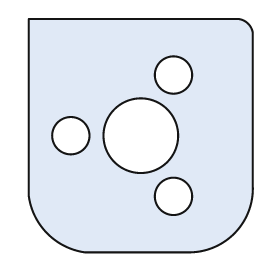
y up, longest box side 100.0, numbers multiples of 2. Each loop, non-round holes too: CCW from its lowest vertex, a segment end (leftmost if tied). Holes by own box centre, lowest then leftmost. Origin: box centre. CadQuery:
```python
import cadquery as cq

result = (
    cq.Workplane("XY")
    .moveTo(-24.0, -50.0)
    .lineTo(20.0, -50.0)
    .threePointArc((40.0, -42.0), (48.0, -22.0))
    .lineTo(48.0, 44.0)
    .threePointArc((46.0, 48.0), (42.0, 50.0))
    .lineTo(-48.0, 50.0)
    .lineTo(-48.0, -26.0)
    .threePointArc((-40.0, -42.0), (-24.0, -50.0))
    .close()
    .moveTo(14.0, -26.0)
    .circle(8.0)
    .moveTo(-30.0, 0.0)
    .circle(8.0)
    .moveTo(0.0, 0.0)
    .circle(16.0)
    .moveTo(14.0, 26.0)
    .circle(8.0)
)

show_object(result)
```